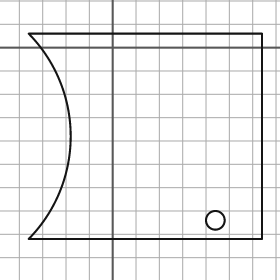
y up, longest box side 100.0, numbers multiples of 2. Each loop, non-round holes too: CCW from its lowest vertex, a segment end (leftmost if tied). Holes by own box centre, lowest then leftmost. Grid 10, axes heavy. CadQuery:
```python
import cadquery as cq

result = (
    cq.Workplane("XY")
    .moveTo(-36.0, -82.0)
    .lineTo(64.0, -82.0)
    .lineTo(64.0, 6.0)
    .lineTo(-36.0, 6.0)
    .threePointArc((-18.0, -38.0), (-36.0, -82.0))
    .close()
    .moveTo(44.0, -74.0)
    .circle(4.0)
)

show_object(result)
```